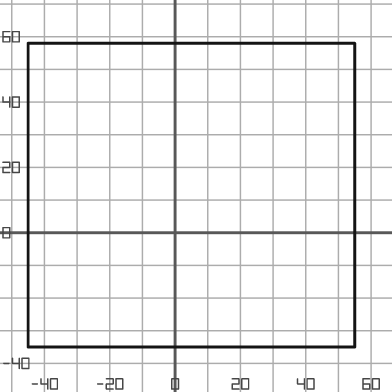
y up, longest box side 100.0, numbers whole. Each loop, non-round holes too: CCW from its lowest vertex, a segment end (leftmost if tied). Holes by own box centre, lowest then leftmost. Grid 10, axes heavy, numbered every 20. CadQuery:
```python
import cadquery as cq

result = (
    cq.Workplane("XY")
    .moveTo(-45.0, -35.0)
    .lineTo(55.0, -35.0)
    .lineTo(55.0, 58.0)
    .lineTo(-45.0, 58.0)
    .close()
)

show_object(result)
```